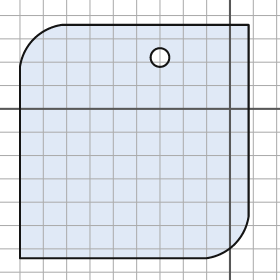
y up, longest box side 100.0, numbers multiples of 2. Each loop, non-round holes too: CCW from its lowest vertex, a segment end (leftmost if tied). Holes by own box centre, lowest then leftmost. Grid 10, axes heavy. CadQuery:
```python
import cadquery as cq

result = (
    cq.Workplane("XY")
    .moveTo(-90.0, -64.0)
    .lineTo(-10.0, -64.0)
    .threePointArc((2.0, -58.0), (8.0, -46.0))
    .lineTo(8.0, 36.0)
    .lineTo(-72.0, 36.0)
    .threePointArc((-84.0, 30.0), (-90.0, 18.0))
    .close()
    .moveTo(-30.0, 22.0)
    .circle(4.0)
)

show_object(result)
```